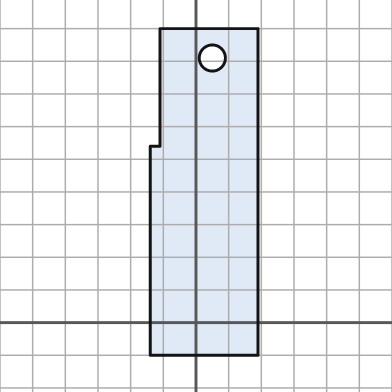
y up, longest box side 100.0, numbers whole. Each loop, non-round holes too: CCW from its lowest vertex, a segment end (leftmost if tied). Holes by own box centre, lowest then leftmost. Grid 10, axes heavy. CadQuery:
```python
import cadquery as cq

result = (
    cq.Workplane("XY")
    .moveTo(-14.0, -10.0)
    .lineTo(19.0, -10.0)
    .lineTo(19.0, 90.0)
    .lineTo(-11.0, 90.0)
    .lineTo(-11.0, 54.0)
    .lineTo(-14.0, 54.0)
    .close()
    .moveTo(5.0, 81.0)
    .circle(4.0)
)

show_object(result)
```